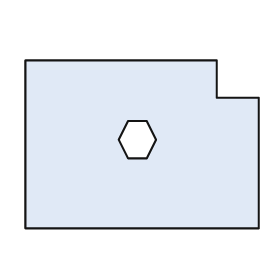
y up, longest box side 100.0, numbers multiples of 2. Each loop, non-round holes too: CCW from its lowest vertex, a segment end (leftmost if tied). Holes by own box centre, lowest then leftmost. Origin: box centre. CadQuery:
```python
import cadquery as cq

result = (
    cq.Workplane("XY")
    .moveTo(-50.0, -36.0)
    .lineTo(50.0, -36.0)
    .lineTo(50.0, 20.0)
    .lineTo(32.0, 20.0)
    .lineTo(32.0, 36.0)
    .lineTo(-50.0, 36.0)
    .close()
    .moveTo(-6.0, -6.0)
    .lineTo(2.0, -6.0)
    .lineTo(6.0, 2.0)
    .lineTo(2.0, 10.0)
    .lineTo(-6.0, 10.0)
    .lineTo(-10.0, 2.0)
    .close()
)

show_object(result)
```